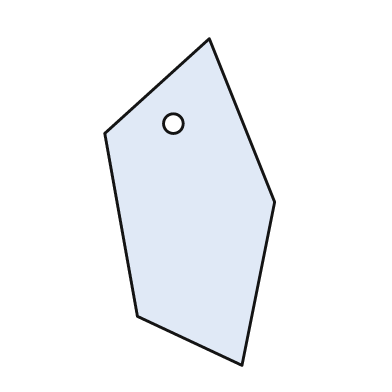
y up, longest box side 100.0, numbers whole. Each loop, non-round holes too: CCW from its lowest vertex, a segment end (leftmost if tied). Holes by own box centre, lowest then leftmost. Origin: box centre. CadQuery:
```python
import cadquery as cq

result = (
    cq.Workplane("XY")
    .moveTo(16.0, -50.0)
    .lineTo(26.0, 0.0)
    .lineTo(6.0, 50.0)
    .lineTo(-26.0, 21.0)
    .lineTo(-16.0, -35.0)
    .close()
    .moveTo(-5.0, 24.0)
    .circle(3.0)
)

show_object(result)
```